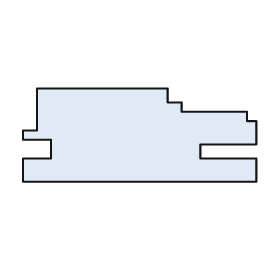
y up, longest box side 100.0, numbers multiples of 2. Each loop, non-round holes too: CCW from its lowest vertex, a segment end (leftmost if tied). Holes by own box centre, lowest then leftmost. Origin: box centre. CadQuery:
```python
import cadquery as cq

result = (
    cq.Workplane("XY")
    .moveTo(-50.0, -20.0)
    .lineTo(50.0, -20.0)
    .lineTo(50.0, -10.0)
    .lineTo(26.0, -10.0)
    .lineTo(26.0, -4.0)
    .lineTo(50.0, -4.0)
    .lineTo(50.0, 6.0)
    .lineTo(46.0, 6.0)
    .lineTo(46.0, 10.0)
    .lineTo(18.0, 10.0)
    .lineTo(18.0, 14.0)
    .lineTo(12.0, 14.0)
    .lineTo(12.0, 20.0)
    .lineTo(-44.0, 20.0)
    .lineTo(-44.0, 2.0)
    .lineTo(-50.0, 2.0)
    .lineTo(-50.0, -2.0)
    .lineTo(-38.0, -2.0)
    .lineTo(-38.0, -10.0)
    .lineTo(-50.0, -10.0)
    .close()
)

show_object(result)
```